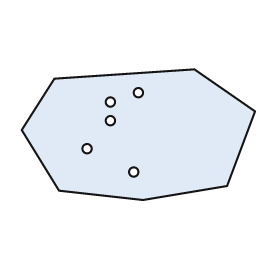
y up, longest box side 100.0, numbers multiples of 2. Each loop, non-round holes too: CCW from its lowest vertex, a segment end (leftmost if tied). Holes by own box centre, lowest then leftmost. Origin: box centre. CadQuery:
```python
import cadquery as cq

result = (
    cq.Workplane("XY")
    .moveTo(2.0, -28.0)
    .lineTo(38.0, -22.0)
    .lineTo(50.0, 10.0)
    .lineTo(24.0, 28.0)
    .lineTo(-36.0, 24.0)
    .lineTo(-50.0, 2.0)
    .lineTo(-34.0, -24.0)
    .close()
    .moveTo(-2.0, -16.0)
    .circle(2.0)
    .moveTo(-22.0, -6.0)
    .circle(2.0)
    .moveTo(-12.0, 6.0)
    .circle(2.0)
    .moveTo(-12.0, 14.0)
    .circle(2.0)
    .moveTo(0.0, 18.0)
    .circle(2.0)
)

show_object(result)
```